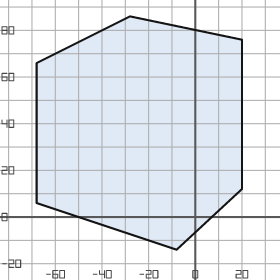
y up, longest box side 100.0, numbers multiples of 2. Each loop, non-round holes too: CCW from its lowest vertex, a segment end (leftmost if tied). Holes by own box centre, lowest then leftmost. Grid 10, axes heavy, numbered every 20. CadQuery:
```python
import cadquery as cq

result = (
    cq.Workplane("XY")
    .moveTo(-8.0, -14.0)
    .lineTo(20.0, 12.0)
    .lineTo(20.0, 76.0)
    .lineTo(-28.0, 86.0)
    .lineTo(-68.0, 66.0)
    .lineTo(-68.0, 6.0)
    .close()
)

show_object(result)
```